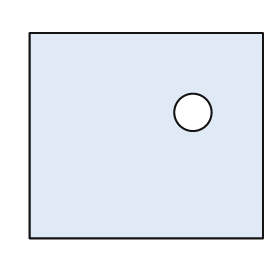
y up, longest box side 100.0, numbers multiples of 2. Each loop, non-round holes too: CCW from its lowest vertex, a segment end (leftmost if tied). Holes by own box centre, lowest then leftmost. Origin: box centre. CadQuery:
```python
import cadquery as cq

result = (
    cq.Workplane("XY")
    .moveTo(-50.0, -44.0)
    .lineTo(50.0, -44.0)
    .lineTo(50.0, 44.0)
    .lineTo(-50.0, 44.0)
    .close()
    .moveTo(20.0, 10.0)
    .circle(8.0)
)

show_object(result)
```